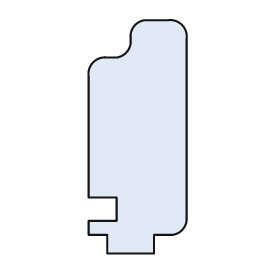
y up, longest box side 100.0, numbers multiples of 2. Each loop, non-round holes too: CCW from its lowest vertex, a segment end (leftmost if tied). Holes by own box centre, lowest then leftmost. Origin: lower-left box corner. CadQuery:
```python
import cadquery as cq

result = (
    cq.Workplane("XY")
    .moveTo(8.0, 0.0)
    .lineTo(28.0, 0.0)
    .lineTo(28.0, 8.0)
    .lineTo(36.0, 8.0)
    .threePointArc((40.0, 10.0), (42.0, 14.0))
    .lineTo(42.0, 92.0)
    .threePointArc((40.0, 98.0), (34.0, 100.0))
    .lineTo(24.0, 100.0)
    .threePointArc((20.0, 98.0), (18.0, 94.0))
    .lineTo(18.0, 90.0)
    .threePointArc((16.0, 86.0), (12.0, 84.0))
    .lineTo(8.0, 84.0)
    .threePointArc((2.0, 82.0), (0.0, 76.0))
    .lineTo(0.0, 24.0)
    .lineTo(12.0, 24.0)
    .lineTo(12.0, 14.0)
    .lineTo(0.0, 14.0)
    .lineTo(0.0, 8.0)
    .lineTo(8.0, 8.0)
    .close()
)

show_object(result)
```